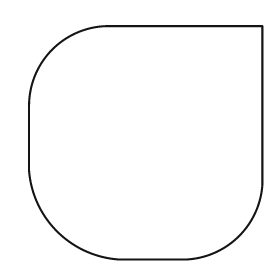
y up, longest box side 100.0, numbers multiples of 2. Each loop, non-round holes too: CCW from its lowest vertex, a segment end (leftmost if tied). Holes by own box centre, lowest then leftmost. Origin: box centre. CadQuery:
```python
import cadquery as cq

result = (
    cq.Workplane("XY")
    .moveTo(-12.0, -50.0)
    .lineTo(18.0, -50.0)
    .threePointArc((40.0, -40.0), (50.0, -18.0))
    .lineTo(50.0, 50.0)
    .lineTo(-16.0, 50.0)
    .threePointArc((-40.0, 40.0), (-50.0, 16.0))
    .lineTo(-50.0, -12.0)
    .threePointArc((-38.0, -38.0), (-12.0, -50.0))
    .close()
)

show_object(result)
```